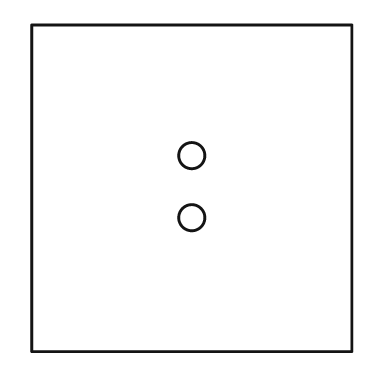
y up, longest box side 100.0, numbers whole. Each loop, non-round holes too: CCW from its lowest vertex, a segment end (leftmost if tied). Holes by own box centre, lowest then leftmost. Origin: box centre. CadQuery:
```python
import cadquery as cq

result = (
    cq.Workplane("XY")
    .moveTo(-49.0, -50.0)
    .lineTo(49.0, -50.0)
    .lineTo(49.0, 50.0)
    .lineTo(-49.0, 50.0)
    .close()
    .moveTo(0.0, -9.0)
    .circle(4.0)
    .moveTo(0.0, 10.0)
    .circle(4.0)
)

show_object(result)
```